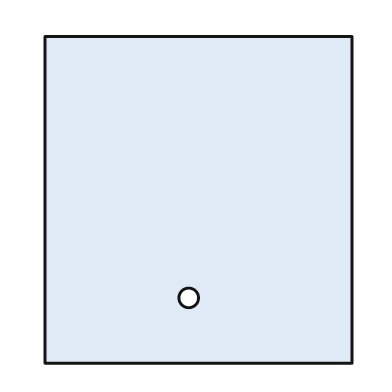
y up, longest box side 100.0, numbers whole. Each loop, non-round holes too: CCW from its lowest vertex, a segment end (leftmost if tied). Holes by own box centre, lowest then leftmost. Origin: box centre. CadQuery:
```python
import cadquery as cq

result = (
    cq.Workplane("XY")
    .moveTo(-47.0, -50.0)
    .lineTo(47.0, -50.0)
    .lineTo(47.0, 50.0)
    .lineTo(-47.0, 50.0)
    .close()
    .moveTo(-3.0, -30.0)
    .circle(3.0)
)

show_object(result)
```